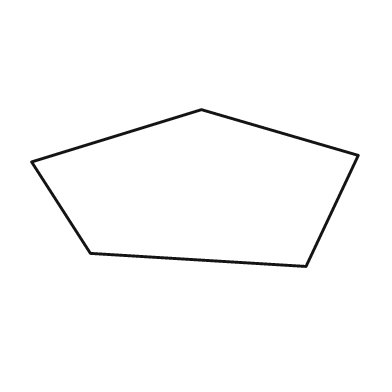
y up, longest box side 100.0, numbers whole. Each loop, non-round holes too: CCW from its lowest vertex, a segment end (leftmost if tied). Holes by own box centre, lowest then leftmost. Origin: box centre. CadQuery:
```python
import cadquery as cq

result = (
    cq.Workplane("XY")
    .moveTo(34.0, -24.0)
    .lineTo(50.0, 10.0)
    .lineTo(2.0, 24.0)
    .lineTo(-50.0, 8.0)
    .lineTo(-32.0, -20.0)
    .close()
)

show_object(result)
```